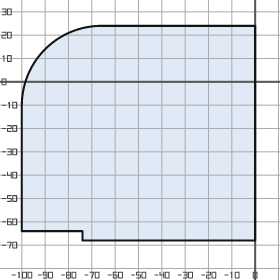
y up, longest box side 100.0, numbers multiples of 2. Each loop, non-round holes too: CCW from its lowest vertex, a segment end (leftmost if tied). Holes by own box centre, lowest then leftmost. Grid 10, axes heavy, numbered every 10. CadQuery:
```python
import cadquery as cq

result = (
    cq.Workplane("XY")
    .moveTo(-74.0, -68.0)
    .lineTo(0.0, -68.0)
    .lineTo(0.0, 24.0)
    .lineTo(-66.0, 24.0)
    .threePointArc((-90.0, 14.0), (-100.0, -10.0))
    .lineTo(-100.0, -64.0)
    .lineTo(-74.0, -64.0)
    .close()
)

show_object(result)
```